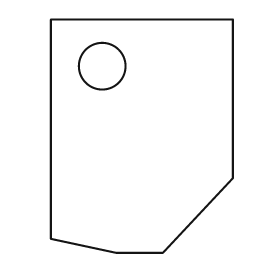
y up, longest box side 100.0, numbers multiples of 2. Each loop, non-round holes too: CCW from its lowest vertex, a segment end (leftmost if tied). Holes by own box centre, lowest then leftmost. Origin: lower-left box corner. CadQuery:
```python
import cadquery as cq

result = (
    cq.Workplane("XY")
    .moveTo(28.0, 0.0)
    .lineTo(48.0, 0.0)
    .lineTo(78.0, 32.0)
    .lineTo(78.0, 100.0)
    .lineTo(0.0, 100.0)
    .lineTo(0.0, 6.0)
    .close()
    .moveTo(22.0, 80.0)
    .circle(10.0)
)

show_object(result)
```